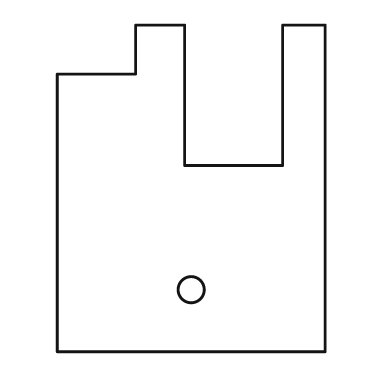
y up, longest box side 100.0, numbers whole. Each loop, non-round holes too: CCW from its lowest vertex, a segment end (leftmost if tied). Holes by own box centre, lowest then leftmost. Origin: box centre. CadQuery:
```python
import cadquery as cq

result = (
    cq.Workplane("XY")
    .moveTo(-41.0, -50.0)
    .lineTo(41.0, -50.0)
    .lineTo(41.0, 50.0)
    .lineTo(28.0, 50.0)
    .lineTo(28.0, 7.0)
    .lineTo(-2.0, 7.0)
    .lineTo(-2.0, 50.0)
    .lineTo(-17.0, 50.0)
    .lineTo(-17.0, 35.0)
    .lineTo(-41.0, 35.0)
    .close()
    .moveTo(0.0, -31.0)
    .circle(4.0)
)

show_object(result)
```